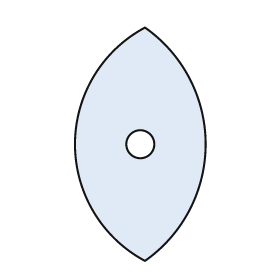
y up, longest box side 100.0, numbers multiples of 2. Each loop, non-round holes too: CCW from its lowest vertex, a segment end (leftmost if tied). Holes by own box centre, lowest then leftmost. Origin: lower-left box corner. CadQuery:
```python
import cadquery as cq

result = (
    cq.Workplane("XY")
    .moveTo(30.0, 0.0)
    .threePointArc((56.0, 50.0), (30.0, 100.0))
    .threePointArc((0.0, 50.0), (30.0, 0.0))
    .close()
    .moveTo(28.0, 50.0)
    .circle(6.0)
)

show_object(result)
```